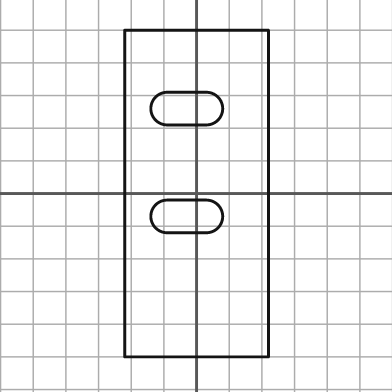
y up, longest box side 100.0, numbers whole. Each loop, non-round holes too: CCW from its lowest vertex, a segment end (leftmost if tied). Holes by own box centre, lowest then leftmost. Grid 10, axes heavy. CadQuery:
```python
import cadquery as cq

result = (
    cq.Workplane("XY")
    .moveTo(-22.0, -50.0)
    .lineTo(22.0, -50.0)
    .lineTo(22.0, 50.0)
    .lineTo(-22.0, 50.0)
    .close()
    .moveTo(-9.0, -12.0)
    .lineTo(3.0, -12.0)
    .threePointArc((8.0, -7.0), (3.0, -2.0))
    .lineTo(-9.0, -2.0)
    .threePointArc((-14.0, -7.0), (-9.0, -12.0))
    .close()
    .moveTo(-9.0, 21.0)
    .lineTo(3.0, 21.0)
    .threePointArc((8.0, 26.0), (3.0, 31.0))
    .lineTo(-9.0, 31.0)
    .threePointArc((-14.0, 26.0), (-9.0, 21.0))
    .close()
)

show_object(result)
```